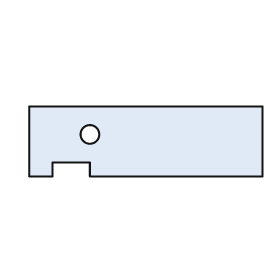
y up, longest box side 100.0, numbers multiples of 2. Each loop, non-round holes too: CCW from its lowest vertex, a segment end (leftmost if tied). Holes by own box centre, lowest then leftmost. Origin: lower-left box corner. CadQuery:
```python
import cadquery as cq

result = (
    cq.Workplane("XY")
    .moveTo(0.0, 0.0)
    .lineTo(10.0, 0.0)
    .lineTo(10.0, 6.0)
    .lineTo(26.0, 6.0)
    .lineTo(26.0, 0.0)
    .lineTo(100.0, 0.0)
    .lineTo(100.0, 30.0)
    .lineTo(0.0, 30.0)
    .close()
    .moveTo(26.0, 18.0)
    .circle(4.0)
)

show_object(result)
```